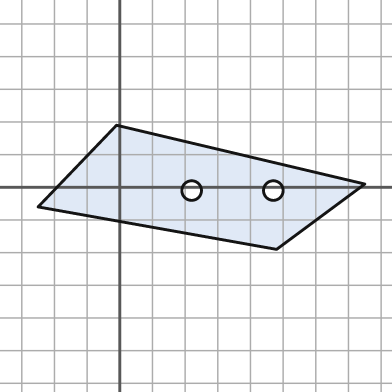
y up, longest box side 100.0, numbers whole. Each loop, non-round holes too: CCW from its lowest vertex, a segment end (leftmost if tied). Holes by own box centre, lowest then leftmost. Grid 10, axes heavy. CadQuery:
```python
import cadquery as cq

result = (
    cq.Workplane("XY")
    .moveTo(48.0, -19.0)
    .lineTo(75.0, 1.0)
    .lineTo(-1.0, 19.0)
    .lineTo(-25.0, -6.0)
    .close()
    .moveTo(22.0, -1.0)
    .circle(3.0)
    .moveTo(47.0, -1.0)
    .circle(3.0)
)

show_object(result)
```